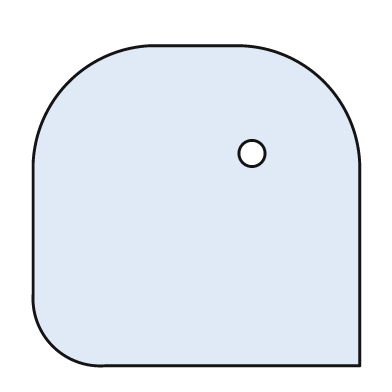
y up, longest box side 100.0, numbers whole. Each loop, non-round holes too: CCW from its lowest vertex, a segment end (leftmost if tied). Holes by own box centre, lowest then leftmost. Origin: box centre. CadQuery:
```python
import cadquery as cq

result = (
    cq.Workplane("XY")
    .moveTo(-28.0, -49.0)
    .lineTo(50.0, -49.0)
    .lineTo(50.0, 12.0)
    .threePointArc((39.0, 38.0), (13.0, 49.0))
    .lineTo(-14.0, 49.0)
    .threePointArc((-39.0, 38.0), (-50.0, 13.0))
    .lineTo(-50.0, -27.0)
    .threePointArc((-44.0, -43.0), (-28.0, -49.0))
    .close()
    .moveTo(17.0, 16.0)
    .circle(4.0)
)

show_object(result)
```